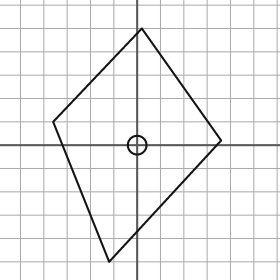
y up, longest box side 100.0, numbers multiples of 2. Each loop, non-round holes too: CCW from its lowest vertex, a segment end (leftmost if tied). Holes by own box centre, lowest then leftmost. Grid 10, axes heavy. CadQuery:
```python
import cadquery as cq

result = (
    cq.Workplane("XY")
    .moveTo(-12.0, -50.0)
    .lineTo(36.0, 2.0)
    .lineTo(2.0, 50.0)
    .lineTo(-36.0, 10.0)
    .close()
    .moveTo(0.0, 0.0)
    .circle(4.0)
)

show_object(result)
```